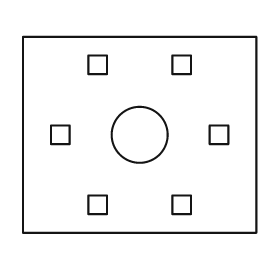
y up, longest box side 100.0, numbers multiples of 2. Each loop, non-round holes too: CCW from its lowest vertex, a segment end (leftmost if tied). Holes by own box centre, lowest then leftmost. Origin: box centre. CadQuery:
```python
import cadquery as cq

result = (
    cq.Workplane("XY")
    .moveTo(-50.0, -42.0)
    .lineTo(50.0, -42.0)
    .lineTo(50.0, 42.0)
    .lineTo(-50.0, 42.0)
    .close()
    .moveTo(-22.0, -34.0)
    .lineTo(-14.0, -34.0)
    .lineTo(-14.0, -26.0)
    .lineTo(-22.0, -26.0)
    .close()
    .moveTo(14.0, -34.0)
    .lineTo(22.0, -34.0)
    .lineTo(22.0, -26.0)
    .lineTo(14.0, -26.0)
    .close()
    .moveTo(-38.0, -4.0)
    .lineTo(-30.0, -4.0)
    .lineTo(-30.0, 4.0)
    .lineTo(-38.0, 4.0)
    .close()
    .moveTo(0.0, 0.0)
    .circle(12.0)
    .moveTo(30.0, -4.0)
    .lineTo(38.0, -4.0)
    .lineTo(38.0, 4.0)
    .lineTo(30.0, 4.0)
    .close()
    .moveTo(-22.0, 26.0)
    .lineTo(-14.0, 26.0)
    .lineTo(-14.0, 34.0)
    .lineTo(-22.0, 34.0)
    .close()
    .moveTo(14.0, 26.0)
    .lineTo(22.0, 26.0)
    .lineTo(22.0, 34.0)
    .lineTo(14.0, 34.0)
    .close()
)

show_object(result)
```